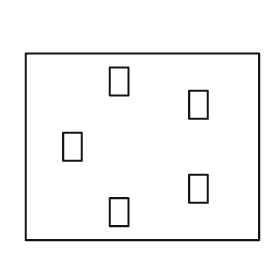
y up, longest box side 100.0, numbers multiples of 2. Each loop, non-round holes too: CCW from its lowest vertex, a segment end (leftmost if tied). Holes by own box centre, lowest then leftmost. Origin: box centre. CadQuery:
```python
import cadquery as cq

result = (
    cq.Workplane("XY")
    .moveTo(-50.0, -40.0)
    .lineTo(50.0, -40.0)
    .lineTo(50.0, 40.0)
    .lineTo(-50.0, 40.0)
    .close()
    .moveTo(-14.0, -34.0)
    .lineTo(-6.0, -34.0)
    .lineTo(-6.0, -22.0)
    .lineTo(-14.0, -22.0)
    .close()
    .moveTo(20.0, -24.0)
    .lineTo(28.0, -24.0)
    .lineTo(28.0, -12.0)
    .lineTo(20.0, -12.0)
    .close()
    .moveTo(-34.0, -6.0)
    .lineTo(-26.0, -6.0)
    .lineTo(-26.0, 6.0)
    .lineTo(-34.0, 6.0)
    .close()
    .moveTo(20.0, 12.0)
    .lineTo(28.0, 12.0)
    .lineTo(28.0, 24.0)
    .lineTo(20.0, 24.0)
    .close()
    .moveTo(-14.0, 22.0)
    .lineTo(-6.0, 22.0)
    .lineTo(-6.0, 34.0)
    .lineTo(-14.0, 34.0)
    .close()
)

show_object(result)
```